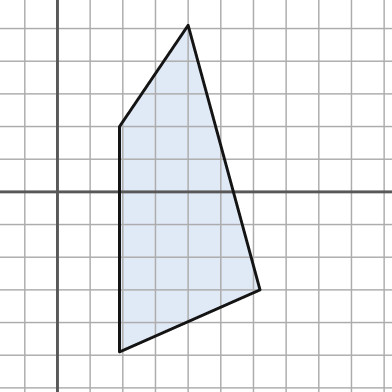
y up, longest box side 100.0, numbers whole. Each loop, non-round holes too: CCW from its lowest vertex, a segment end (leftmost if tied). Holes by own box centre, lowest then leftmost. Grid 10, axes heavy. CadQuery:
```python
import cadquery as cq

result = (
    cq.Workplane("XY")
    .moveTo(19.0, -49.0)
    .lineTo(62.0, -30.0)
    .lineTo(40.0, 51.0)
    .lineTo(19.0, 20.0)
    .close()
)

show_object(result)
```